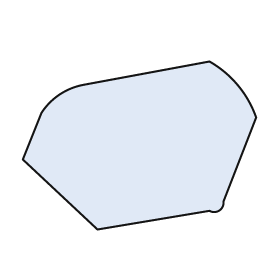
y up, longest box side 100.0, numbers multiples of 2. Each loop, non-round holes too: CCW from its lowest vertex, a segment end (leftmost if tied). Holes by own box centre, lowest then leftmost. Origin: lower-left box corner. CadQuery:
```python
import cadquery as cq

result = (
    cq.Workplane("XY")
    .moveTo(32.0, 0.0)
    .lineTo(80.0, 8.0)
    .threePointArc((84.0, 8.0), (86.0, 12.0))
    .lineTo(100.0, 48.0)
    .threePointArc((92.0, 62.0), (80.0, 72.0))
    .lineTo(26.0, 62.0)
    .threePointArc((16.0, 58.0), (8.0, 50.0))
    .lineTo(0.0, 30.0)
    .close()
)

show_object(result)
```